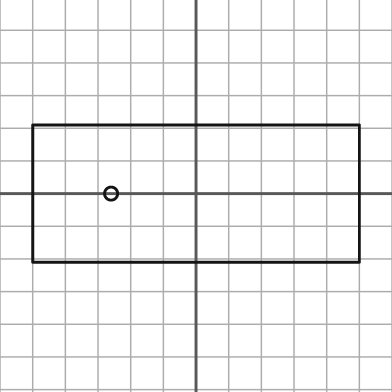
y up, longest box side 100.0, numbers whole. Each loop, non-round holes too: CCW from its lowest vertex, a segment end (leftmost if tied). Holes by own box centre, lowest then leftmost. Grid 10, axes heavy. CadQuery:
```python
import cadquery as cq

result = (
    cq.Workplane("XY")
    .moveTo(-50.0, -21.0)
    .lineTo(50.0, -21.0)
    .lineTo(50.0, 21.0)
    .lineTo(-50.0, 21.0)
    .close()
    .moveTo(-26.0, 0.0)
    .circle(2.0)
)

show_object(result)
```